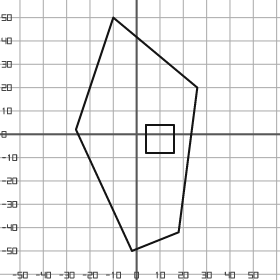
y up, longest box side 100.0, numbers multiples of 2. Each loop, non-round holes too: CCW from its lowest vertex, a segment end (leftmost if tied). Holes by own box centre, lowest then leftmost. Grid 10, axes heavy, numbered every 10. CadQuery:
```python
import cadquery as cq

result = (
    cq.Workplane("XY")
    .moveTo(-2.0, -50.0)
    .lineTo(18.0, -42.0)
    .lineTo(26.0, 20.0)
    .lineTo(-10.0, 50.0)
    .lineTo(-26.0, 2.0)
    .close()
    .moveTo(4.0, -8.0)
    .lineTo(16.0, -8.0)
    .lineTo(16.0, 4.0)
    .lineTo(4.0, 4.0)
    .close()
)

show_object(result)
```